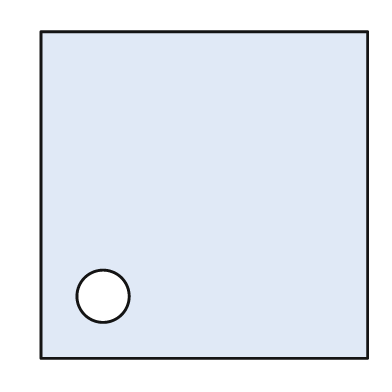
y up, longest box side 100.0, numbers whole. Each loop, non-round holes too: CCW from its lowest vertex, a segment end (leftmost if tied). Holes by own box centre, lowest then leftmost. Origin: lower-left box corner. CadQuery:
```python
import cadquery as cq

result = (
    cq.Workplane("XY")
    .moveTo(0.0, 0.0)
    .lineTo(100.0, 0.0)
    .lineTo(100.0, 100.0)
    .lineTo(0.0, 100.0)
    .close()
    .moveTo(19.0, 19.0)
    .circle(8.0)
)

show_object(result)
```